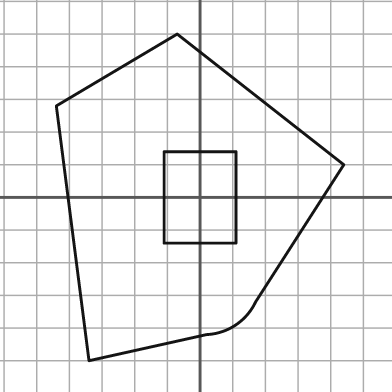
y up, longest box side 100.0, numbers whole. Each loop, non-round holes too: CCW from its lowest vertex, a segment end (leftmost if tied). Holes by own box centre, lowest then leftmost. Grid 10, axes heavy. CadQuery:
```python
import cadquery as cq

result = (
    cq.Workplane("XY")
    .moveTo(-34.0, -50.0)
    .lineTo(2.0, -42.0)
    .threePointArc((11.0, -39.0), (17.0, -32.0))
    .lineTo(44.0, 10.0)
    .lineTo(-7.0, 50.0)
    .lineTo(-44.0, 28.0)
    .close()
    .moveTo(-11.0, -14.0)
    .lineTo(11.0, -14.0)
    .lineTo(11.0, 14.0)
    .lineTo(-11.0, 14.0)
    .close()
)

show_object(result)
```